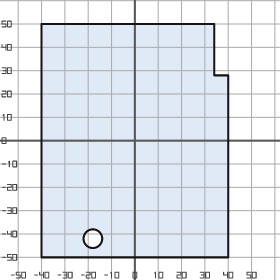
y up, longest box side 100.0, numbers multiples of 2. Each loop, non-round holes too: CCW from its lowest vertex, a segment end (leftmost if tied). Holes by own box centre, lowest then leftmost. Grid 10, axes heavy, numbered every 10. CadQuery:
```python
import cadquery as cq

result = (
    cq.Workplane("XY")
    .moveTo(-40.0, -50.0)
    .lineTo(40.0, -50.0)
    .lineTo(40.0, 28.0)
    .lineTo(34.0, 28.0)
    .lineTo(34.0, 50.0)
    .lineTo(-40.0, 50.0)
    .close()
    .moveTo(-18.0, -42.0)
    .circle(4.0)
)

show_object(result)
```